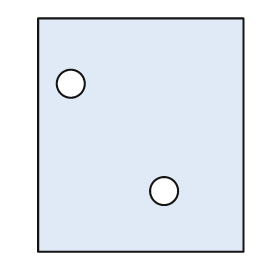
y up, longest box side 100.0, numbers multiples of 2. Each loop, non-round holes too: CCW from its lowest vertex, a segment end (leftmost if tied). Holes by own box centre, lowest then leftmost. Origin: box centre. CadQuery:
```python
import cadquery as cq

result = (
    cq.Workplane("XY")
    .moveTo(-44.0, -50.0)
    .lineTo(44.0, -50.0)
    .lineTo(44.0, 50.0)
    .lineTo(-44.0, 50.0)
    .close()
    .moveTo(10.0, -24.0)
    .circle(6.0)
    .moveTo(-30.0, 22.0)
    .circle(6.0)
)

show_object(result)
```